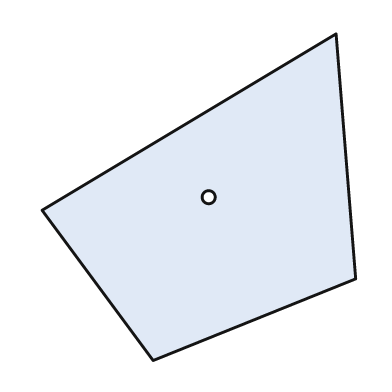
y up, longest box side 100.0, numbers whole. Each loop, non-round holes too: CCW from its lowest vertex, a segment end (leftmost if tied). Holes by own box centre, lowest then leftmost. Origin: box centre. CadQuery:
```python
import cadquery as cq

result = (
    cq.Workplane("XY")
    .moveTo(-14.0, -50.0)
    .lineTo(48.0, -25.0)
    .lineTo(42.0, 50.0)
    .lineTo(-48.0, -4.0)
    .close()
    .moveTo(3.0, 0.0)
    .circle(2.0)
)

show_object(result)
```